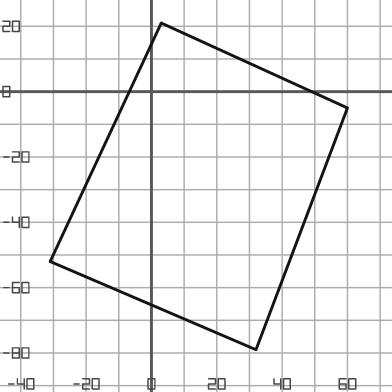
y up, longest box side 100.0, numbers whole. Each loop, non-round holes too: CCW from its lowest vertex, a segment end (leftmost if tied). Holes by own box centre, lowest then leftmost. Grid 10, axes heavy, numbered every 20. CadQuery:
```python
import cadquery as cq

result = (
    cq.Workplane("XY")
    .moveTo(32.0, -79.0)
    .lineTo(60.0, -5.0)
    .lineTo(3.0, 21.0)
    .lineTo(-31.0, -52.0)
    .close()
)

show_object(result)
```